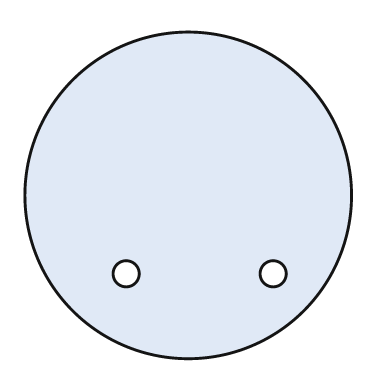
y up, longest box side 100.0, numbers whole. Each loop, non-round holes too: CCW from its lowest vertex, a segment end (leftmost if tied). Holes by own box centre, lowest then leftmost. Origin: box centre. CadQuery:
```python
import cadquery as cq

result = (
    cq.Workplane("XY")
    .moveTo(0.0, 0.0)
    .circle(50.0)
    .moveTo(-19.0, -24.0)
    .circle(4.0)
    .moveTo(26.0, -24.0)
    .circle(4.0)
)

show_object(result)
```